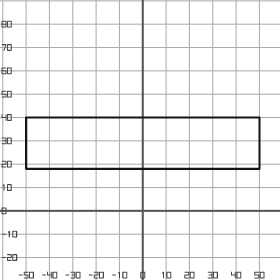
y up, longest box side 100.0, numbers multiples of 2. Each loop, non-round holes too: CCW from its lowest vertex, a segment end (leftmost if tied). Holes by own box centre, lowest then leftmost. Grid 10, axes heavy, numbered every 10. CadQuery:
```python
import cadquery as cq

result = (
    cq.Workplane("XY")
    .moveTo(-50.0, 18.0)
    .lineTo(50.0, 18.0)
    .lineTo(50.0, 40.0)
    .lineTo(-50.0, 40.0)
    .close()
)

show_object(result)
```